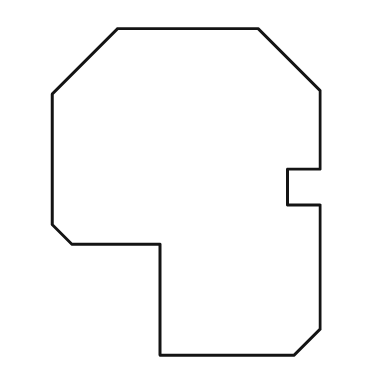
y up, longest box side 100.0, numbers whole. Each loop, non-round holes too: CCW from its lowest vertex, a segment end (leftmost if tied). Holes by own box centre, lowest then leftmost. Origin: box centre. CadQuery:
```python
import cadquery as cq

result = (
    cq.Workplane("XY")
    .moveTo(-8.0, -50.0)
    .lineTo(33.0, -50.0)
    .lineTo(41.0, -42.0)
    .lineTo(41.0, -4.0)
    .lineTo(31.0, -4.0)
    .lineTo(31.0, 7.0)
    .lineTo(41.0, 7.0)
    .lineTo(41.0, 31.0)
    .lineTo(22.0, 50.0)
    .lineTo(-21.0, 50.0)
    .lineTo(-41.0, 30.0)
    .lineTo(-41.0, -10.0)
    .lineTo(-35.0, -16.0)
    .lineTo(-8.0, -16.0)
    .close()
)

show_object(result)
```